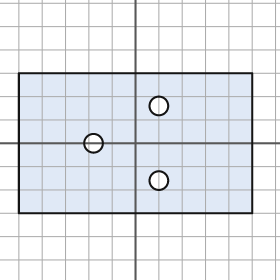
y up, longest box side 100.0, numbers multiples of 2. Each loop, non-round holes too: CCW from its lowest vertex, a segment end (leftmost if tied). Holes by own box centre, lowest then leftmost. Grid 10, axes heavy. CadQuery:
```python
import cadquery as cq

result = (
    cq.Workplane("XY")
    .moveTo(-50.0, -30.0)
    .lineTo(50.0, -30.0)
    .lineTo(50.0, 30.0)
    .lineTo(-50.0, 30.0)
    .close()
    .moveTo(10.0, -16.0)
    .circle(4.0)
    .moveTo(-18.0, 0.0)
    .circle(4.0)
    .moveTo(10.0, 16.0)
    .circle(4.0)
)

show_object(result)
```